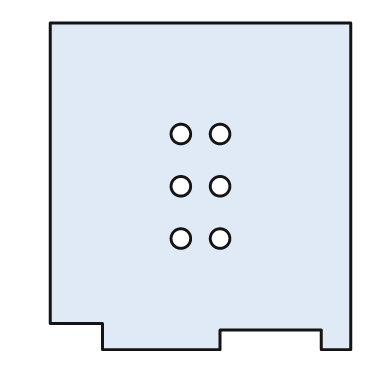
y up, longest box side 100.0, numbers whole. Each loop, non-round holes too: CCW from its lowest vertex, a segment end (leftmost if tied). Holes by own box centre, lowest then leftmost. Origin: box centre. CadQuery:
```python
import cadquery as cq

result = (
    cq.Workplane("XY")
    .moveTo(-30.0, -50.0)
    .lineTo(6.0, -50.0)
    .lineTo(6.0, -44.0)
    .lineTo(37.0, -44.0)
    .lineTo(37.0, -50.0)
    .lineTo(46.0, -50.0)
    .lineTo(46.0, 50.0)
    .lineTo(-46.0, 50.0)
    .lineTo(-46.0, -42.0)
    .lineTo(-30.0, -42.0)
    .close()
    .moveTo(-6.0, -16.0)
    .circle(3.0)
    .moveTo(6.0, -16.0)
    .circle(3.0)
    .moveTo(-6.0, 0.0)
    .circle(3.0)
    .moveTo(6.0, 0.0)
    .circle(3.0)
    .moveTo(-6.0, 16.0)
    .circle(3.0)
    .moveTo(6.0, 16.0)
    .circle(3.0)
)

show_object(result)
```